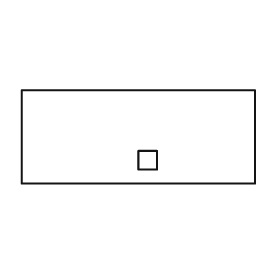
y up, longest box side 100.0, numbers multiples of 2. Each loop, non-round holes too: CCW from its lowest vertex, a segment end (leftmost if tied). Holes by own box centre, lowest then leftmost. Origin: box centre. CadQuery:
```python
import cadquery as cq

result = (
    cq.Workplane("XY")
    .moveTo(-50.0, -20.0)
    .lineTo(50.0, -20.0)
    .lineTo(50.0, 20.0)
    .lineTo(-50.0, 20.0)
    .close()
    .moveTo(0.0, -14.0)
    .lineTo(8.0, -14.0)
    .lineTo(8.0, -6.0)
    .lineTo(0.0, -6.0)
    .close()
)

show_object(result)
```